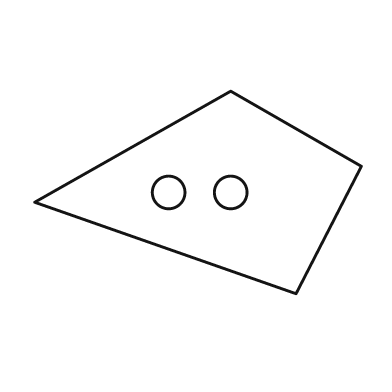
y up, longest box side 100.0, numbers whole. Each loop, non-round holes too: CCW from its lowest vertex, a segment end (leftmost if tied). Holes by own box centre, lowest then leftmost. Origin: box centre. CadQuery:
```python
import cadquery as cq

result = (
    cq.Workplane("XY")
    .moveTo(30.0, -31.0)
    .lineTo(50.0, 8.0)
    .lineTo(10.0, 31.0)
    .lineTo(-50.0, -3.0)
    .close()
    .moveTo(-9.0, 0.0)
    .circle(5.0)
    .moveTo(10.0, 0.0)
    .circle(5.0)
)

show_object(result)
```